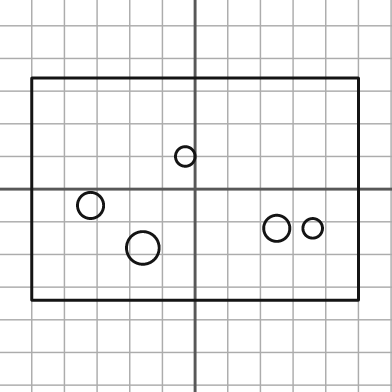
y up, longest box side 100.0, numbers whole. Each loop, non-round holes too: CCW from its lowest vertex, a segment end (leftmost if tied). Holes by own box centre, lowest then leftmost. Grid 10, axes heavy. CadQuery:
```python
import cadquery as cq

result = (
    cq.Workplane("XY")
    .moveTo(-50.0, -34.0)
    .lineTo(50.0, -34.0)
    .lineTo(50.0, 34.0)
    .lineTo(-50.0, 34.0)
    .close()
    .moveTo(-16.0, -18.0)
    .circle(5.0)
    .moveTo(25.0, -12.0)
    .circle(4.0)
    .moveTo(36.0, -12.0)
    .circle(3.0)
    .moveTo(-32.0, -5.0)
    .circle(4.0)
    .moveTo(-3.0, 10.0)
    .circle(3.0)
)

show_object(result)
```